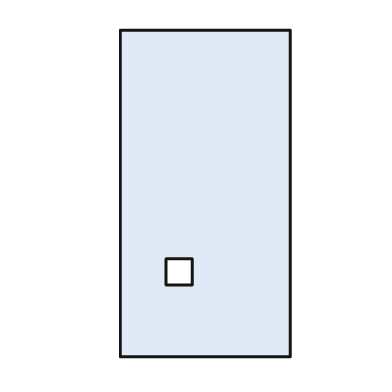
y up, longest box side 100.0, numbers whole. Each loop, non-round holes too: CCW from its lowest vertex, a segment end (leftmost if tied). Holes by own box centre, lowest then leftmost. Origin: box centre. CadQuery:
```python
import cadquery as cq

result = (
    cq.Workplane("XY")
    .moveTo(-26.0, -50.0)
    .lineTo(26.0, -50.0)
    .lineTo(26.0, 50.0)
    .lineTo(-26.0, 50.0)
    .close()
    .moveTo(-12.0, -28.0)
    .lineTo(-4.0, -28.0)
    .lineTo(-4.0, -20.0)
    .lineTo(-12.0, -20.0)
    .close()
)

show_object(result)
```